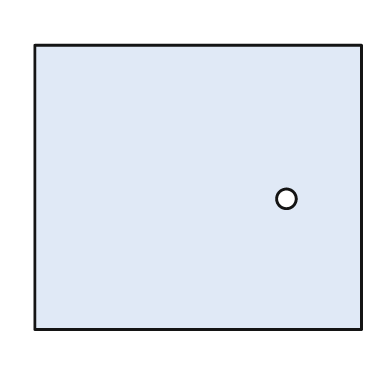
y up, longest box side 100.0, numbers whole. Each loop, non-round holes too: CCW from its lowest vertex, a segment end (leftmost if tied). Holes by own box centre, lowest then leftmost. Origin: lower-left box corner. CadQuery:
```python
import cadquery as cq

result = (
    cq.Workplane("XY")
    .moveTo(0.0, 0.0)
    .lineTo(100.0, 0.0)
    .lineTo(100.0, 87.0)
    .lineTo(0.0, 87.0)
    .close()
    .moveTo(77.0, 40.0)
    .circle(3.0)
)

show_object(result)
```